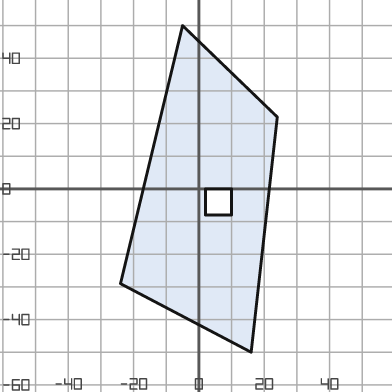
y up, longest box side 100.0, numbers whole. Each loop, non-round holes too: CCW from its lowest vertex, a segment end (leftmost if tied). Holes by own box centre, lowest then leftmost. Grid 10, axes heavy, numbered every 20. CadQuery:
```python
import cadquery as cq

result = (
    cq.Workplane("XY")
    .moveTo(16.0, -50.0)
    .lineTo(24.0, 22.0)
    .lineTo(-5.0, 50.0)
    .lineTo(-24.0, -29.0)
    .close()
    .moveTo(2.0, -8.0)
    .lineTo(10.0, -8.0)
    .lineTo(10.0, 0.0)
    .lineTo(2.0, 0.0)
    .close()
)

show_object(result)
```